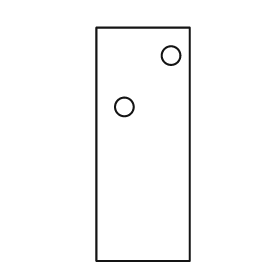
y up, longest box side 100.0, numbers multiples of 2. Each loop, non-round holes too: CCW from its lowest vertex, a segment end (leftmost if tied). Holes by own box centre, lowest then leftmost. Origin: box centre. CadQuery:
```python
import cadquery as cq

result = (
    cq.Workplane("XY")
    .moveTo(-20.0, -50.0)
    .lineTo(20.0, -50.0)
    .lineTo(20.0, 50.0)
    .lineTo(-20.0, 50.0)
    .close()
    .moveTo(-8.0, 16.0)
    .circle(4.0)
    .moveTo(12.0, 38.0)
    .circle(4.0)
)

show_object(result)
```